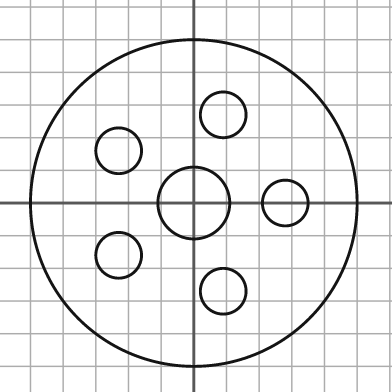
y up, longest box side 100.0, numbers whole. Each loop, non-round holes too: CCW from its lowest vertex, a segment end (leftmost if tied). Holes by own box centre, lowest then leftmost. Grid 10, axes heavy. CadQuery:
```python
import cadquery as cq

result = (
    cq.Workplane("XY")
    .moveTo(0.0, 0.0)
    .circle(50.0)
    .moveTo(9.0, -27.0)
    .circle(7.0)
    .moveTo(-23.0, -16.0)
    .circle(7.0)
    .moveTo(0.0, 0.0)
    .circle(11.0)
    .moveTo(28.0, 0.0)
    .circle(7.0)
    .moveTo(-23.0, 16.0)
    .circle(7.0)
    .moveTo(9.0, 27.0)
    .circle(7.0)
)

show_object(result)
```